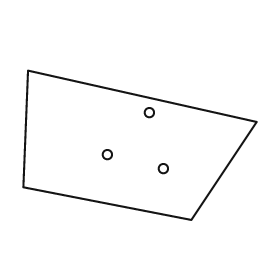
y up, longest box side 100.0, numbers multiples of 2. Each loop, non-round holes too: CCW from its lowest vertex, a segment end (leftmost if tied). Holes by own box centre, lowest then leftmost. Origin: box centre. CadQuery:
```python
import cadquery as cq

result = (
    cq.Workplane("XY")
    .moveTo(22.0, -32.0)
    .lineTo(50.0, 10.0)
    .lineTo(-48.0, 32.0)
    .lineTo(-50.0, -18.0)
    .close()
    .moveTo(10.0, -10.0)
    .circle(2.0)
    .moveTo(-14.0, -4.0)
    .circle(2.0)
    .moveTo(4.0, 14.0)
    .circle(2.0)
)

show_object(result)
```